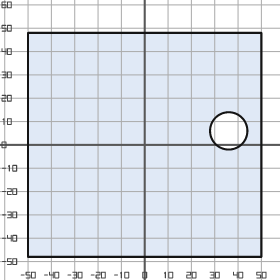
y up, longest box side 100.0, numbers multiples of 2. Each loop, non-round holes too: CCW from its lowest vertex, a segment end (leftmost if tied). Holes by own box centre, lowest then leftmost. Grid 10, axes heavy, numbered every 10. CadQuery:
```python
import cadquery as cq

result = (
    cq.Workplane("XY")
    .moveTo(-50.0, -48.0)
    .lineTo(50.0, -48.0)
    .lineTo(50.0, 48.0)
    .lineTo(-50.0, 48.0)
    .close()
    .moveTo(36.0, 6.0)
    .circle(8.0)
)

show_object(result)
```